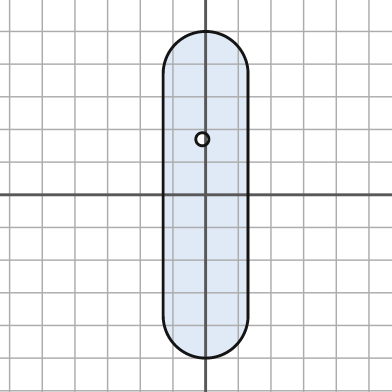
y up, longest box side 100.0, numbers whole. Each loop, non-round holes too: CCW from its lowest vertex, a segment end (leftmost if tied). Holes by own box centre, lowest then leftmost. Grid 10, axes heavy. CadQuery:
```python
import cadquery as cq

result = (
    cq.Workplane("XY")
    .moveTo(-13.0, -37.0)
    .threePointArc((0.0, -50.0), (13.0, -37.0))
    .lineTo(13.0, 37.0)
    .threePointArc((0.0, 50.0), (-13.0, 37.0))
    .close()
    .moveTo(-1.0, 17.0)
    .circle(2.0)
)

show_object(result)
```